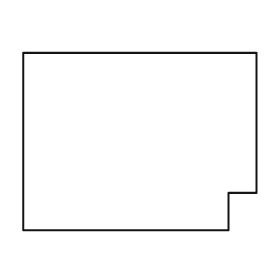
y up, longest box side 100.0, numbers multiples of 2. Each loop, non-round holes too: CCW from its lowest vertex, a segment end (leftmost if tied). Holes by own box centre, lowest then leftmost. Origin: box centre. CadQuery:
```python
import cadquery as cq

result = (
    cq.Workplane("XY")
    .moveTo(-50.0, -38.0)
    .lineTo(38.0, -38.0)
    .lineTo(38.0, -22.0)
    .lineTo(50.0, -22.0)
    .lineTo(50.0, 38.0)
    .lineTo(-50.0, 38.0)
    .close()
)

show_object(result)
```